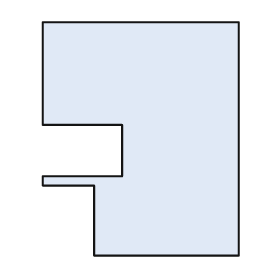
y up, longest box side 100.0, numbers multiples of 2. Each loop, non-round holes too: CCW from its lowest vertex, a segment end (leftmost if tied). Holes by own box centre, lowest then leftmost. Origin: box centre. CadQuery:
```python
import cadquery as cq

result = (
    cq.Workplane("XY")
    .moveTo(-20.0, -50.0)
    .lineTo(42.0, -50.0)
    .lineTo(42.0, 50.0)
    .lineTo(-42.0, 50.0)
    .lineTo(-42.0, 6.0)
    .lineTo(-8.0, 6.0)
    .lineTo(-8.0, -16.0)
    .lineTo(-42.0, -16.0)
    .lineTo(-42.0, -20.0)
    .lineTo(-20.0, -20.0)
    .close()
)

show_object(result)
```